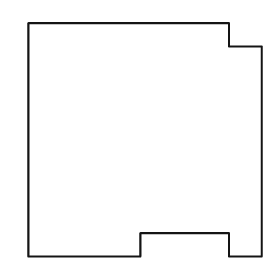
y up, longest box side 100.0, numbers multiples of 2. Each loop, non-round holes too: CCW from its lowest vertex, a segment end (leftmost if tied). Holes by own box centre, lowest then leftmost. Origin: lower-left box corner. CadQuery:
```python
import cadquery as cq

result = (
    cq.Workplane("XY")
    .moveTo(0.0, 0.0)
    .lineTo(48.0, 0.0)
    .lineTo(48.0, 10.0)
    .lineTo(86.0, 10.0)
    .lineTo(86.0, 0.0)
    .lineTo(100.0, 0.0)
    .lineTo(100.0, 90.0)
    .lineTo(86.0, 90.0)
    .lineTo(86.0, 100.0)
    .lineTo(0.0, 100.0)
    .close()
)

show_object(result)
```